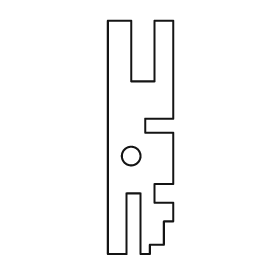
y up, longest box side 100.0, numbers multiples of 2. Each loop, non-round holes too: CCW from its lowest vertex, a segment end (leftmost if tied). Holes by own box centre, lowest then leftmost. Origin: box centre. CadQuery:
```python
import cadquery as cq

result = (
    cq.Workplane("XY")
    .moveTo(-14.0, -50.0)
    .lineTo(-6.0, -50.0)
    .lineTo(-6.0, -24.0)
    .lineTo(0.0, -24.0)
    .lineTo(0.0, -50.0)
    .lineTo(4.0, -50.0)
    .lineTo(4.0, -46.0)
    .lineTo(10.0, -46.0)
    .lineTo(10.0, -36.0)
    .lineTo(14.0, -36.0)
    .lineTo(14.0, -28.0)
    .lineTo(6.0, -28.0)
    .lineTo(6.0, -20.0)
    .lineTo(14.0, -20.0)
    .lineTo(14.0, 2.0)
    .lineTo(2.0, 2.0)
    .lineTo(2.0, 8.0)
    .lineTo(14.0, 8.0)
    .lineTo(14.0, 50.0)
    .lineTo(6.0, 50.0)
    .lineTo(6.0, 24.0)
    .lineTo(-4.0, 24.0)
    .lineTo(-4.0, 50.0)
    .lineTo(-14.0, 50.0)
    .close()
    .moveTo(-4.0, -8.0)
    .circle(4.0)
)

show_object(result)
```